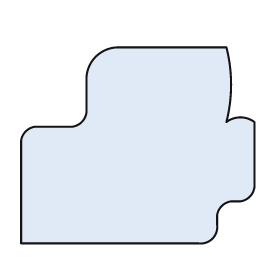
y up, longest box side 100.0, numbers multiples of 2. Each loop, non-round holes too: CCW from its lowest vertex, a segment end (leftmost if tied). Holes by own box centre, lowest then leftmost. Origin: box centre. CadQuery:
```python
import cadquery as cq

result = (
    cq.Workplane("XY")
    .moveTo(-50.0, -42.0)
    .lineTo(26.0, -42.0)
    .threePointArc((32.0, -40.0), (34.0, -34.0))
    .lineTo(34.0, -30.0)
    .threePointArc((36.0, -26.0), (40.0, -24.0))
    .lineTo(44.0, -24.0)
    .threePointArc((48.0, -22.0), (50.0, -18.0))
    .lineTo(50.0, 10.0)
    .threePointArc((44.0, 12.0), (38.0, 10.0))
    .threePointArc((40.0, 26.0), (38.0, 42.0))
    .lineTo(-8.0, 42.0)
    .threePointArc((-18.0, 38.0), (-22.0, 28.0))
    .lineTo(-22.0, 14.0)
    .threePointArc((-24.0, 10.0), (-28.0, 8.0))
    .lineTo(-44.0, 8.0)
    .threePointArc((-48.0, 6.0), (-50.0, 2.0))
    .close()
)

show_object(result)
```